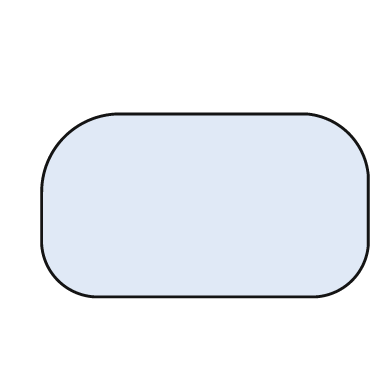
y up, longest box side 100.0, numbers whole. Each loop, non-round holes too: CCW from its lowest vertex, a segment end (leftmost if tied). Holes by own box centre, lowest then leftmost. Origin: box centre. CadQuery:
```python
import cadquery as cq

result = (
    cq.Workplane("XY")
    .moveTo(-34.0, -28.0)
    .lineTo(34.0, -28.0)
    .threePointArc((45.0, -23.0), (50.0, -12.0))
    .lineTo(50.0, 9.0)
    .threePointArc((44.0, 22.0), (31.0, 28.0))
    .lineTo(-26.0, 28.0)
    .threePointArc((-43.0, 21.0), (-50.0, 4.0))
    .lineTo(-50.0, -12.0)
    .threePointArc((-45.0, -23.0), (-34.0, -28.0))
    .close()
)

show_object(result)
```